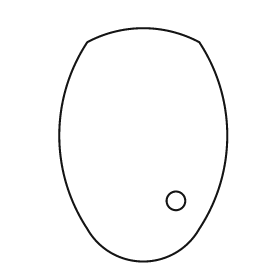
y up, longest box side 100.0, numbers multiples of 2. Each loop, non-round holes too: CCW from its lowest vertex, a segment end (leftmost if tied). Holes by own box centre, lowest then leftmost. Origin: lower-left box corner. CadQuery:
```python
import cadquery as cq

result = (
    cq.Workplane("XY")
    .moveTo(12.0, 14.0)
    .threePointArc((36.0, 0.0), (60.0, 14.0))
    .threePointArc((72.0, 54.0), (60.0, 94.0))
    .threePointArc((36.0, 100.0), (12.0, 94.0))
    .threePointArc((0.0, 54.0), (12.0, 14.0))
    .close()
    .moveTo(50.0, 26.0)
    .circle(4.0)
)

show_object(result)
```